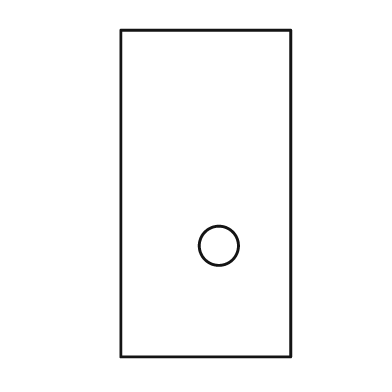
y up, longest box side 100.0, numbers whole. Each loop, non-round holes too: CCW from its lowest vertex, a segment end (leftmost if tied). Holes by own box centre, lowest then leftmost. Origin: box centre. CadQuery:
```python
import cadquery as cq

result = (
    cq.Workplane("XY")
    .moveTo(-26.0, -50.0)
    .lineTo(26.0, -50.0)
    .lineTo(26.0, 50.0)
    .lineTo(-26.0, 50.0)
    .close()
    .moveTo(4.0, -16.0)
    .circle(6.0)
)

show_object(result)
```